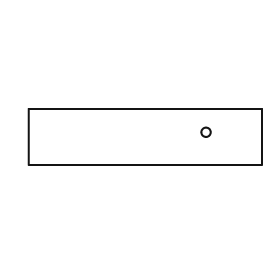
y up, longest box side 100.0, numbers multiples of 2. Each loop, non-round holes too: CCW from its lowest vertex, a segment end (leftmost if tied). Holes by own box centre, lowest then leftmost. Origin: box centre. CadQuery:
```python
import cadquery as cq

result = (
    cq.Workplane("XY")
    .moveTo(-50.0, -12.0)
    .lineTo(50.0, -12.0)
    .lineTo(50.0, 12.0)
    .lineTo(-50.0, 12.0)
    .close()
    .moveTo(26.0, 2.0)
    .circle(2.0)
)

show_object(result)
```